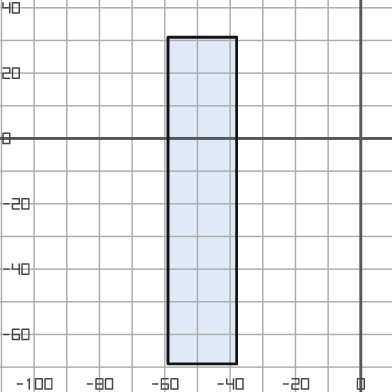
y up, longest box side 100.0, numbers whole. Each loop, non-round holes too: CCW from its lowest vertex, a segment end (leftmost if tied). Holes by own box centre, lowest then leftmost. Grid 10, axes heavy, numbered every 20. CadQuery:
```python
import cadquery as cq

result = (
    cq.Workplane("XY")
    .moveTo(-59.0, -69.0)
    .lineTo(-38.0, -69.0)
    .lineTo(-38.0, 31.0)
    .lineTo(-59.0, 31.0)
    .close()
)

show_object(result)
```